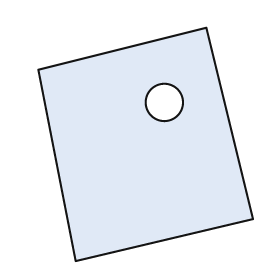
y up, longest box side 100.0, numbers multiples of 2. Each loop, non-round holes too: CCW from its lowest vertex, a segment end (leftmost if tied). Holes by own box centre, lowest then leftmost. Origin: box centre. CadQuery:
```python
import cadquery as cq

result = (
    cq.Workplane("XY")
    .moveTo(-30.0, -50.0)
    .lineTo(46.0, -32.0)
    .lineTo(26.0, 50.0)
    .lineTo(-46.0, 32.0)
    .close()
    .moveTo(8.0, 18.0)
    .circle(8.0)
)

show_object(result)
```